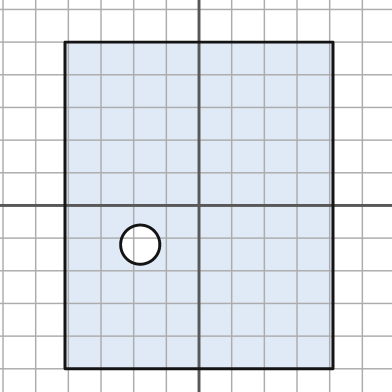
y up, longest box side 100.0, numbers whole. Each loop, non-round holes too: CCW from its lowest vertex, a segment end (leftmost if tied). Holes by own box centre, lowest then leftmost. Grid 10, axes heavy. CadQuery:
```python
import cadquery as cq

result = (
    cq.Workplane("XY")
    .moveTo(-41.0, -50.0)
    .lineTo(41.0, -50.0)
    .lineTo(41.0, 50.0)
    .lineTo(-41.0, 50.0)
    .close()
    .moveTo(-18.0, -12.0)
    .circle(6.0)
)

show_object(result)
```